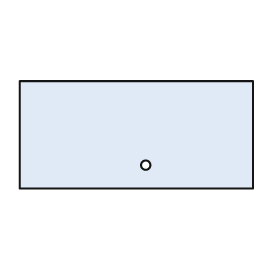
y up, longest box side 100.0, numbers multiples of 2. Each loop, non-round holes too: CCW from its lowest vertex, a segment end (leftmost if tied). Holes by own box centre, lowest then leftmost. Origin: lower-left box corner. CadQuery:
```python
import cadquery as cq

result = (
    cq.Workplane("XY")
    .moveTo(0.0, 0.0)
    .lineTo(100.0, 0.0)
    .lineTo(100.0, 46.0)
    .lineTo(0.0, 46.0)
    .close()
    .moveTo(54.0, 10.0)
    .circle(2.0)
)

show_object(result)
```